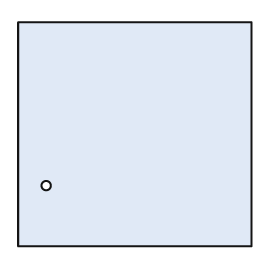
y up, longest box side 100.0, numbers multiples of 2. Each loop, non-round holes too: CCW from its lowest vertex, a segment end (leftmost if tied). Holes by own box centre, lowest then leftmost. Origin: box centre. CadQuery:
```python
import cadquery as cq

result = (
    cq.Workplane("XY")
    .moveTo(-50.0, -48.0)
    .lineTo(50.0, -48.0)
    .lineTo(50.0, 48.0)
    .lineTo(-50.0, 48.0)
    .close()
    .moveTo(-38.0, -22.0)
    .circle(2.0)
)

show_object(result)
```